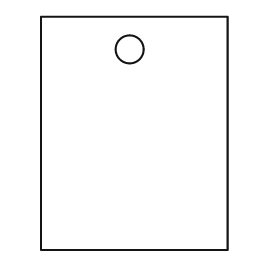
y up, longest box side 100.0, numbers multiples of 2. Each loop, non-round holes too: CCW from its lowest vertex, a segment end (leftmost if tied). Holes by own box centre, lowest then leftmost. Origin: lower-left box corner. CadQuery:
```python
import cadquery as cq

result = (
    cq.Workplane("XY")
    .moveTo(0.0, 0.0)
    .lineTo(80.0, 0.0)
    .lineTo(80.0, 100.0)
    .lineTo(0.0, 100.0)
    .close()
    .moveTo(38.0, 86.0)
    .circle(6.0)
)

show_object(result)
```